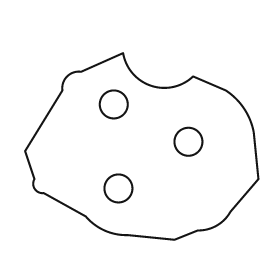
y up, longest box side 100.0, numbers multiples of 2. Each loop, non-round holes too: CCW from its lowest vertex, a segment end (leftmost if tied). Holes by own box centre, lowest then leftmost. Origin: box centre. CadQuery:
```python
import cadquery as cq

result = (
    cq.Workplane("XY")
    .moveTo(14.0, -40.0)
    .lineTo(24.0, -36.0)
    .threePointArc((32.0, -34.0), (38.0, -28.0))
    .lineTo(50.0, -14.0)
    .lineTo(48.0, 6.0)
    .threePointArc((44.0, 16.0), (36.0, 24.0))
    .lineTo(22.0, 30.0)
    .threePointArc((4.0, 26.0), (-8.0, 40.0))
    .lineTo(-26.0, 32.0)
    .threePointArc((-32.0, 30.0), (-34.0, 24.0))
    .lineTo(-50.0, -2.0)
    .lineTo(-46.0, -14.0)
    .threePointArc((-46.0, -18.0), (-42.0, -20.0))
    .lineTo(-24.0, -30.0)
    .threePointArc((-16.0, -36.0), (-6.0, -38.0))
    .close()
    .moveTo(-10.0, -18.0)
    .circle(6.0)
    .moveTo(20.0, 2.0)
    .circle(6.0)
    .moveTo(-12.0, 18.0)
    .circle(6.0)
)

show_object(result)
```